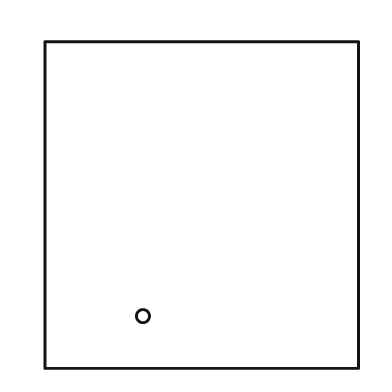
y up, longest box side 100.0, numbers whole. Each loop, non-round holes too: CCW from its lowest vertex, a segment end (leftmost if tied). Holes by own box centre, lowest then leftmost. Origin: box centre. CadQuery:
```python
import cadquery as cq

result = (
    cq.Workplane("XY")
    .moveTo(-48.0, -50.0)
    .lineTo(48.0, -50.0)
    .lineTo(48.0, 50.0)
    .lineTo(-48.0, 50.0)
    .close()
    .moveTo(-18.0, -34.0)
    .circle(2.0)
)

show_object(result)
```